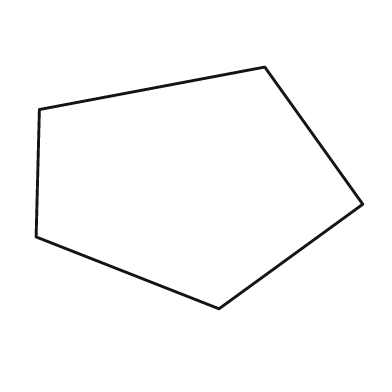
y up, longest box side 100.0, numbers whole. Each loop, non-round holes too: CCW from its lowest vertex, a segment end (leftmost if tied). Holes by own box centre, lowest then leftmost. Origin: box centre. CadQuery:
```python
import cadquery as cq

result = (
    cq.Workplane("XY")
    .moveTo(6.0, -37.0)
    .lineTo(50.0, -5.0)
    .lineTo(20.0, 37.0)
    .lineTo(-49.0, 24.0)
    .lineTo(-50.0, -15.0)
    .close()
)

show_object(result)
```